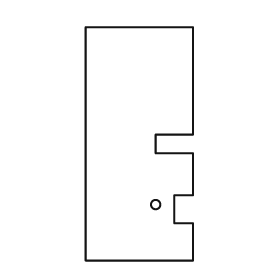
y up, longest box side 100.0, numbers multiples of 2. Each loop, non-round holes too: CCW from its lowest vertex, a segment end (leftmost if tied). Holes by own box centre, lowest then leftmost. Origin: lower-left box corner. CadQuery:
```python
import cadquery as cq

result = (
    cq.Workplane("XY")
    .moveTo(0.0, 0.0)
    .lineTo(46.0, 0.0)
    .lineTo(46.0, 16.0)
    .lineTo(38.0, 16.0)
    .lineTo(38.0, 28.0)
    .lineTo(46.0, 28.0)
    .lineTo(46.0, 46.0)
    .lineTo(30.0, 46.0)
    .lineTo(30.0, 54.0)
    .lineTo(46.0, 54.0)
    .lineTo(46.0, 100.0)
    .lineTo(0.0, 100.0)
    .close()
    .moveTo(30.0, 24.0)
    .circle(2.0)
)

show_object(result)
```